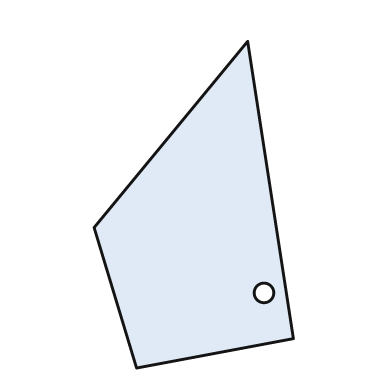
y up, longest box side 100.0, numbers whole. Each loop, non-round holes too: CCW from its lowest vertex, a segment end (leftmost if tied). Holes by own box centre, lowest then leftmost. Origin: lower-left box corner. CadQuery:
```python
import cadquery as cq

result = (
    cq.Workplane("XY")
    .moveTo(13.0, 0.0)
    .lineTo(61.0, 9.0)
    .lineTo(47.0, 100.0)
    .lineTo(0.0, 43.0)
    .close()
    .moveTo(52.0, 23.0)
    .circle(3.0)
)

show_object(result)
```